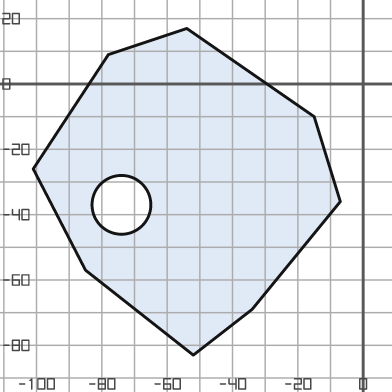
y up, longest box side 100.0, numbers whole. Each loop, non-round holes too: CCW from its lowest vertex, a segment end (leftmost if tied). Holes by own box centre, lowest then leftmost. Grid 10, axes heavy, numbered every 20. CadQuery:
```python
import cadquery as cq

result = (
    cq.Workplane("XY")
    .moveTo(-52.0, -83.0)
    .lineTo(-34.0, -69.0)
    .lineTo(-7.0, -36.0)
    .lineTo(-15.0, -10.0)
    .lineTo(-54.0, 17.0)
    .lineTo(-78.0, 9.0)
    .lineTo(-101.0, -26.0)
    .lineTo(-85.0, -57.0)
    .close()
    .moveTo(-74.0, -37.0)
    .circle(9.0)
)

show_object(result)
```